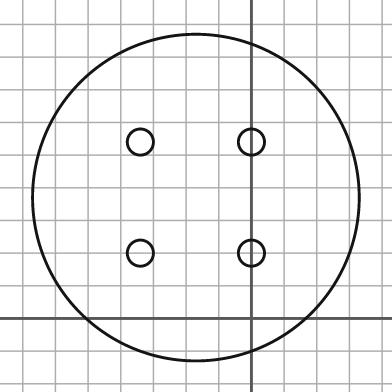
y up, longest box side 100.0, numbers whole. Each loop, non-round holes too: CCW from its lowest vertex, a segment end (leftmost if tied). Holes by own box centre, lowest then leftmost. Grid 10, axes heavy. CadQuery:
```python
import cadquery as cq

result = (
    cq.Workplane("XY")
    .moveTo(-17.0, 37.0)
    .circle(50.0)
    .moveTo(-34.0, 20.0)
    .circle(4.0)
    .moveTo(0.0, 20.0)
    .circle(4.0)
    .moveTo(-34.0, 54.0)
    .circle(4.0)
    .moveTo(0.0, 54.0)
    .circle(4.0)
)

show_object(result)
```